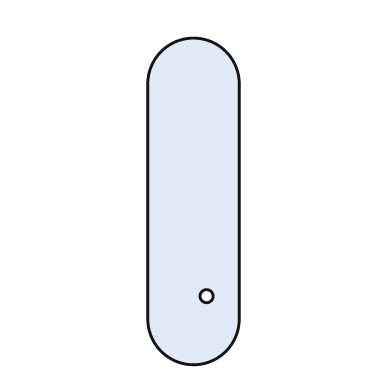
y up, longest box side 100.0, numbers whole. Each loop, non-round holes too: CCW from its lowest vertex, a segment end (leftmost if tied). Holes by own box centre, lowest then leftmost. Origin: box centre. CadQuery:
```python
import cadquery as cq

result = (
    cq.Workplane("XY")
    .moveTo(-14.0, -36.0)
    .threePointArc((0.0, -50.0), (14.0, -36.0))
    .lineTo(14.0, 36.0)
    .threePointArc((0.0, 50.0), (-14.0, 36.0))
    .close()
    .moveTo(4.0, -29.0)
    .circle(2.0)
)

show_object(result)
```